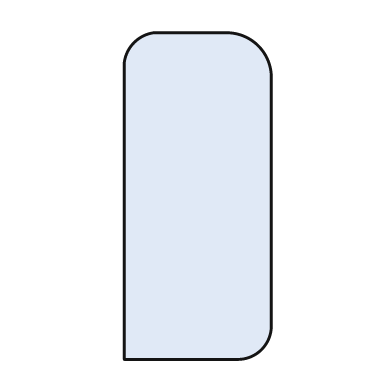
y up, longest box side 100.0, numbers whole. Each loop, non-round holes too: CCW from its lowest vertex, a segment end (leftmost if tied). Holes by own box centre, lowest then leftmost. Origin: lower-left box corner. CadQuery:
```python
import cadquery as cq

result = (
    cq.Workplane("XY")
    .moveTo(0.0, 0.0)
    .lineTo(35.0, 0.0)
    .threePointArc((42.0, 3.0), (45.0, 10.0))
    .lineTo(45.0, 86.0)
    .threePointArc((41.0, 96.0), (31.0, 100.0))
    .lineTo(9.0, 100.0)
    .threePointArc((3.0, 97.0), (0.0, 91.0))
    .close()
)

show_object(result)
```